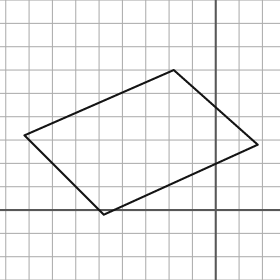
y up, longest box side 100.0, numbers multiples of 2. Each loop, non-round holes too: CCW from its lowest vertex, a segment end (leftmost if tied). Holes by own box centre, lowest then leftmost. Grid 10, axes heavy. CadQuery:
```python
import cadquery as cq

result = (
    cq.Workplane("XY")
    .moveTo(-48.0, -2.0)
    .lineTo(18.0, 28.0)
    .lineTo(-18.0, 60.0)
    .lineTo(-82.0, 32.0)
    .close()
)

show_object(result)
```